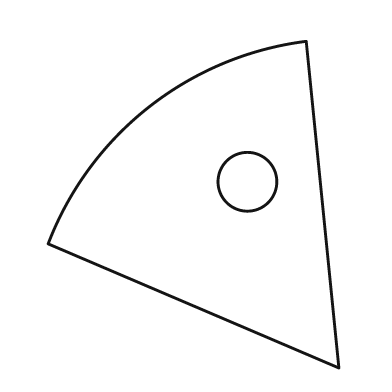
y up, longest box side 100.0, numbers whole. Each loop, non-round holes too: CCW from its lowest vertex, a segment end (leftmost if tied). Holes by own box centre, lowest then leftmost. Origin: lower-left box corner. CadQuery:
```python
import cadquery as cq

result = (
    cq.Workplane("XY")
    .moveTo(89.0, 0.0)
    .lineTo(79.0, 100.0)
    .threePointArc((31.0, 80.0), (0.0, 38.0))
    .close()
    .moveTo(61.0, 57.0)
    .circle(9.0)
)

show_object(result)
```